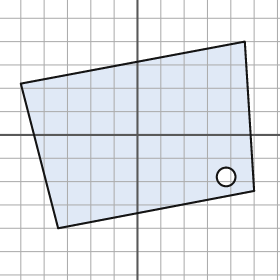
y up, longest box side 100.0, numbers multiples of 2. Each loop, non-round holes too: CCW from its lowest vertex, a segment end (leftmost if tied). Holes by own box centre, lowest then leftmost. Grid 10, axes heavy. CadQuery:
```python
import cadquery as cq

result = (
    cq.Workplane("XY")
    .moveTo(-34.0, -40.0)
    .lineTo(50.0, -24.0)
    .lineTo(46.0, 40.0)
    .lineTo(-50.0, 22.0)
    .close()
    .moveTo(38.0, -18.0)
    .circle(4.0)
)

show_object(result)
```